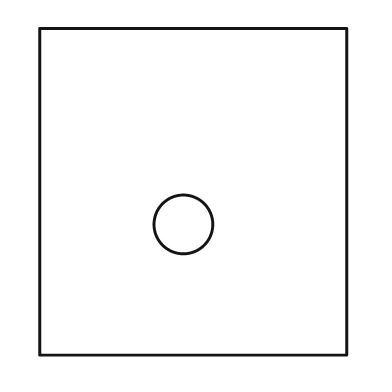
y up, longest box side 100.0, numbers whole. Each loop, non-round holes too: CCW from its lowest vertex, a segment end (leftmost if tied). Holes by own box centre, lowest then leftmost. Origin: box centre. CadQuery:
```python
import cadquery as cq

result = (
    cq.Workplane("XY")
    .moveTo(-47.0, -50.0)
    .lineTo(47.0, -50.0)
    .lineTo(47.0, 50.0)
    .lineTo(-47.0, 50.0)
    .close()
    .moveTo(-3.0, -10.0)
    .circle(9.0)
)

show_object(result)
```